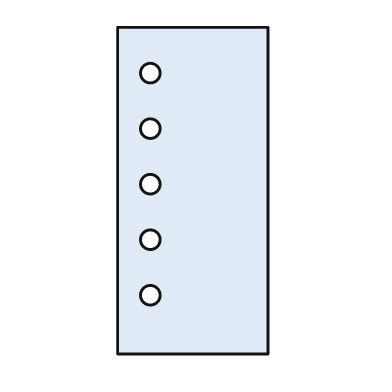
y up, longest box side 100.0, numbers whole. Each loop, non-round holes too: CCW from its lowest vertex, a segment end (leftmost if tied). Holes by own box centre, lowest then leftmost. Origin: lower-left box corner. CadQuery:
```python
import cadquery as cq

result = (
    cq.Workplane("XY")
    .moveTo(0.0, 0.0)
    .lineTo(46.0, 0.0)
    .lineTo(46.0, 100.0)
    .lineTo(0.0, 100.0)
    .close()
    .moveTo(10.0, 18.0)
    .circle(3.0)
    .moveTo(10.0, 35.0)
    .circle(3.0)
    .moveTo(10.0, 52.0)
    .circle(3.0)
    .moveTo(10.0, 69.0)
    .circle(3.0)
    .moveTo(10.0, 86.0)
    .circle(3.0)
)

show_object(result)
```